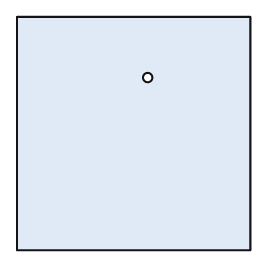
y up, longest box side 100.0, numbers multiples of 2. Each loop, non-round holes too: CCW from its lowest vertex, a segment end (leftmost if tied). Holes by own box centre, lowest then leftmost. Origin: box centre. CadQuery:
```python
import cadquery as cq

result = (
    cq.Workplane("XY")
    .moveTo(-50.0, -50.0)
    .lineTo(50.0, -50.0)
    .lineTo(50.0, 50.0)
    .lineTo(-50.0, 50.0)
    .close()
    .moveTo(6.0, 24.0)
    .circle(2.0)
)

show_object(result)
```